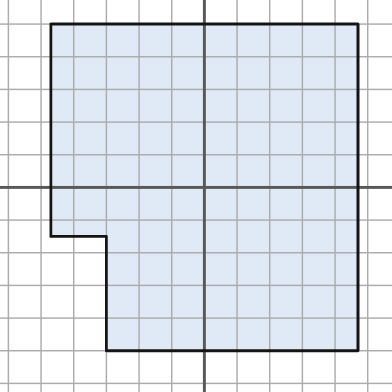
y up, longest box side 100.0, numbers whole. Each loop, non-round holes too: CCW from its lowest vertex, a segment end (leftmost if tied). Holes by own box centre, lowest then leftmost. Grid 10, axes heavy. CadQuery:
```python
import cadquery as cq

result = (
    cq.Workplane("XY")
    .moveTo(-30.0, -50.0)
    .lineTo(47.0, -50.0)
    .lineTo(47.0, 50.0)
    .lineTo(-47.0, 50.0)
    .lineTo(-47.0, -15.0)
    .lineTo(-30.0, -15.0)
    .close()
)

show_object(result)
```